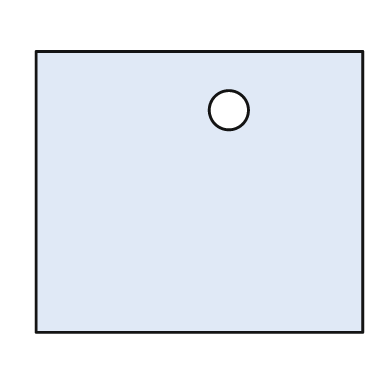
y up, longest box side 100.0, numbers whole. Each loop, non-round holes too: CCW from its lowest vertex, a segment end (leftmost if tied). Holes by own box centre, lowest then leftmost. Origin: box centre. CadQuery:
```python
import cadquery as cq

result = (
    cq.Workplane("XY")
    .moveTo(-50.0, -43.0)
    .lineTo(50.0, -43.0)
    .lineTo(50.0, 43.0)
    .lineTo(-50.0, 43.0)
    .close()
    .moveTo(9.0, 25.0)
    .circle(6.0)
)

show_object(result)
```